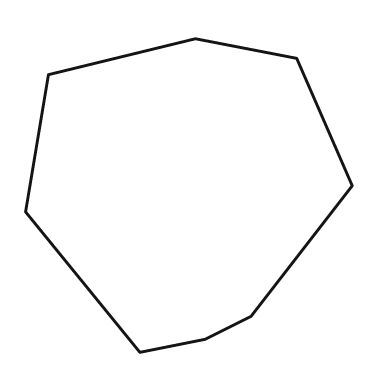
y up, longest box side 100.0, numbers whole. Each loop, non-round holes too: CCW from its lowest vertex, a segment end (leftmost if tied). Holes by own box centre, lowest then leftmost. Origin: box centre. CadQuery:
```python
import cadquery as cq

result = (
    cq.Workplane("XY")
    .moveTo(-15.0, -48.0)
    .lineTo(5.0, -44.0)
    .lineTo(19.0, -37.0)
    .lineTo(50.0, 3.0)
    .lineTo(33.0, 42.0)
    .lineTo(2.0, 48.0)
    .lineTo(-43.0, 37.0)
    .lineTo(-50.0, -5.0)
    .close()
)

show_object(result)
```